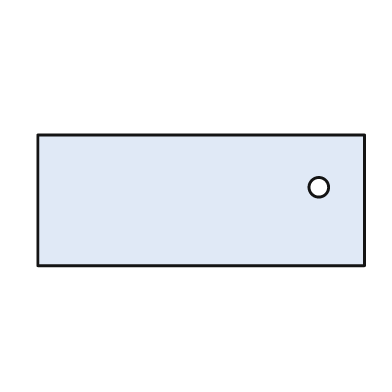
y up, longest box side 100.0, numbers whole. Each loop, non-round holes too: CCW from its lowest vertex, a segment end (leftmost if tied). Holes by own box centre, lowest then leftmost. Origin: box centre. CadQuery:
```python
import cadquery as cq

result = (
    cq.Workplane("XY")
    .moveTo(-50.0, -20.0)
    .lineTo(50.0, -20.0)
    .lineTo(50.0, 20.0)
    .lineTo(-50.0, 20.0)
    .close()
    .moveTo(36.0, 4.0)
    .circle(3.0)
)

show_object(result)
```